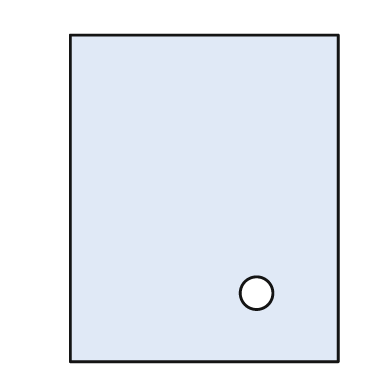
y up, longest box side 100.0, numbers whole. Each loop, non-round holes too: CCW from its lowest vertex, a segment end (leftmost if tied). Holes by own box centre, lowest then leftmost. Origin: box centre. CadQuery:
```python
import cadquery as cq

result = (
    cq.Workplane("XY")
    .moveTo(-41.0, -50.0)
    .lineTo(41.0, -50.0)
    .lineTo(41.0, 50.0)
    .lineTo(-41.0, 50.0)
    .close()
    .moveTo(16.0, -29.0)
    .circle(5.0)
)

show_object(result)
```